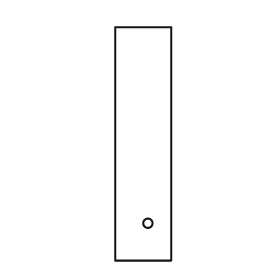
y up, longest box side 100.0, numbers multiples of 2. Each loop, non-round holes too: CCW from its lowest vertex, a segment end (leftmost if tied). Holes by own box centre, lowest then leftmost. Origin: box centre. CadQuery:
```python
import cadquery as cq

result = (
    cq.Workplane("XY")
    .moveTo(-12.0, -50.0)
    .lineTo(12.0, -50.0)
    .lineTo(12.0, 50.0)
    .lineTo(-12.0, 50.0)
    .close()
    .moveTo(2.0, -34.0)
    .circle(2.0)
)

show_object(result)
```